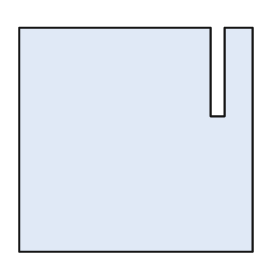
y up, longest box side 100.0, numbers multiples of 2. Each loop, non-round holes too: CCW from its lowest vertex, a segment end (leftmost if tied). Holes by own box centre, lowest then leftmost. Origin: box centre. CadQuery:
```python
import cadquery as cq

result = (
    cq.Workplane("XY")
    .moveTo(-50.0, -48.0)
    .lineTo(50.0, -48.0)
    .lineTo(50.0, 48.0)
    .lineTo(38.0, 48.0)
    .lineTo(38.0, 10.0)
    .lineTo(32.0, 10.0)
    .lineTo(32.0, 48.0)
    .lineTo(-50.0, 48.0)
    .close()
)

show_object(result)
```